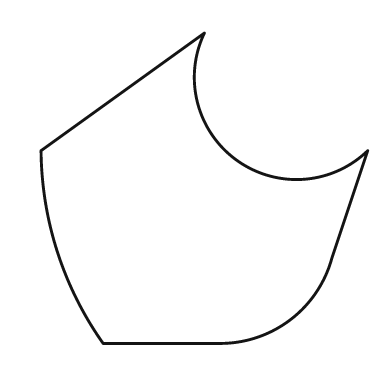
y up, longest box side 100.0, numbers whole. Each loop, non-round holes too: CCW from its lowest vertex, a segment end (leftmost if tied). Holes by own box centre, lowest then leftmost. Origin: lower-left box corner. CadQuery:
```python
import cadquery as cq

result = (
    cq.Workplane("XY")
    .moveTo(19.0, 0.0)
    .lineTo(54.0, 0.0)
    .threePointArc((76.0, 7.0), (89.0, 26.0))
    .lineTo(100.0, 59.0)
    .threePointArc((60.0, 56.0), (50.0, 95.0))
    .lineTo(0.0, 59.0)
    .threePointArc((5.0, 28.0), (19.0, 0.0))
    .close()
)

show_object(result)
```